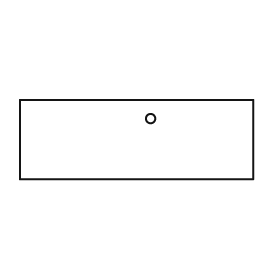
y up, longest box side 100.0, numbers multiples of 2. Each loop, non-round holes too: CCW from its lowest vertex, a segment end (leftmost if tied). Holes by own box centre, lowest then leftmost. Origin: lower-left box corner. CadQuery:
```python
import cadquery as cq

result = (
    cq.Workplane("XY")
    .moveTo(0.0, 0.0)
    .lineTo(100.0, 0.0)
    .lineTo(100.0, 34.0)
    .lineTo(0.0, 34.0)
    .close()
    .moveTo(56.0, 26.0)
    .circle(2.0)
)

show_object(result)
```